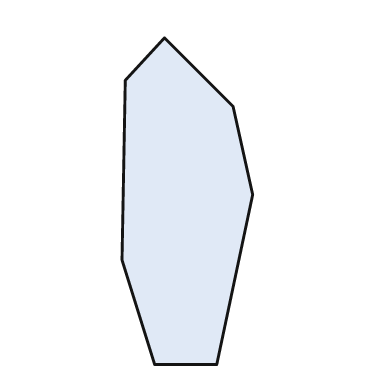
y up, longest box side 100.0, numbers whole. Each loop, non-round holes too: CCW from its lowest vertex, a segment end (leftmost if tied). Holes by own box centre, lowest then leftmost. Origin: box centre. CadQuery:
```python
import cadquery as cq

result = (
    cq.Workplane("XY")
    .moveTo(-10.0, -50.0)
    .lineTo(9.0, -50.0)
    .lineTo(20.0, 2.0)
    .lineTo(14.0, 29.0)
    .lineTo(-7.0, 50.0)
    .lineTo(-19.0, 37.0)
    .lineTo(-20.0, -18.0)
    .close()
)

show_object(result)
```